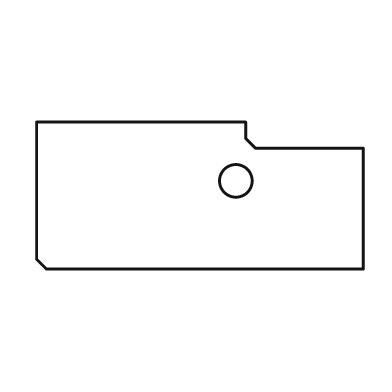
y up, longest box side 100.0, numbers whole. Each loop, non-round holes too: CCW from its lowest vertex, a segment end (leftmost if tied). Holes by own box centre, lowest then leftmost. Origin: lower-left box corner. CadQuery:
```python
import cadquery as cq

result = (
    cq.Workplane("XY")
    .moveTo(3.0, 0.0)
    .lineTo(100.0, 0.0)
    .lineTo(100.0, 37.0)
    .lineTo(67.0, 37.0)
    .lineTo(64.0, 40.0)
    .lineTo(64.0, 45.0)
    .lineTo(0.0, 45.0)
    .lineTo(0.0, 3.0)
    .close()
    .moveTo(61.0, 27.0)
    .circle(5.0)
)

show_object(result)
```